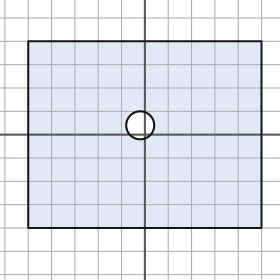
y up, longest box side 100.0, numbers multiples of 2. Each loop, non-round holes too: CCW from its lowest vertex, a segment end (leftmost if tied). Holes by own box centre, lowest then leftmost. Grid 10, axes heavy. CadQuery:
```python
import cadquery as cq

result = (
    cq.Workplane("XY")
    .moveTo(-50.0, -40.0)
    .lineTo(50.0, -40.0)
    .lineTo(50.0, 40.0)
    .lineTo(-50.0, 40.0)
    .close()
    .moveTo(-2.0, 4.0)
    .circle(6.0)
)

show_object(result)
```